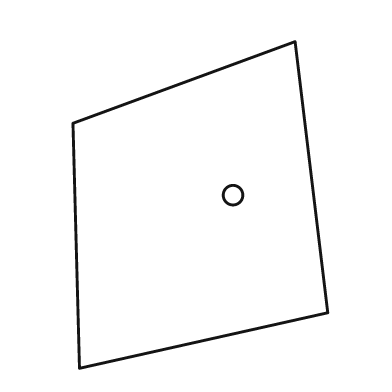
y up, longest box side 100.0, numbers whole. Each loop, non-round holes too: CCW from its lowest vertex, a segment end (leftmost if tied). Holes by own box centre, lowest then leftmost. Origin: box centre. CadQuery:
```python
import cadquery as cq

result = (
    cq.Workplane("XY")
    .moveTo(-37.0, -50.0)
    .lineTo(39.0, -33.0)
    .lineTo(29.0, 50.0)
    .lineTo(-39.0, 25.0)
    .close()
    .moveTo(10.0, 3.0)
    .circle(3.0)
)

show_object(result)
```